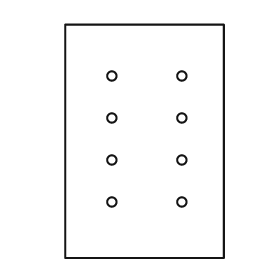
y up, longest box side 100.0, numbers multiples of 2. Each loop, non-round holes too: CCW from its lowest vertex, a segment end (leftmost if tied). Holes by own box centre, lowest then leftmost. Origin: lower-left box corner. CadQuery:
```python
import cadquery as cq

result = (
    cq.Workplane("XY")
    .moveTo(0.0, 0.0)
    .lineTo(68.0, 0.0)
    .lineTo(68.0, 100.0)
    .lineTo(0.0, 100.0)
    .close()
    .moveTo(20.0, 24.0)
    .circle(2.0)
    .moveTo(50.0, 24.0)
    .circle(2.0)
    .moveTo(20.0, 42.0)
    .circle(2.0)
    .moveTo(50.0, 42.0)
    .circle(2.0)
    .moveTo(20.0, 60.0)
    .circle(2.0)
    .moveTo(50.0, 60.0)
    .circle(2.0)
    .moveTo(20.0, 78.0)
    .circle(2.0)
    .moveTo(50.0, 78.0)
    .circle(2.0)
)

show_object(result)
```